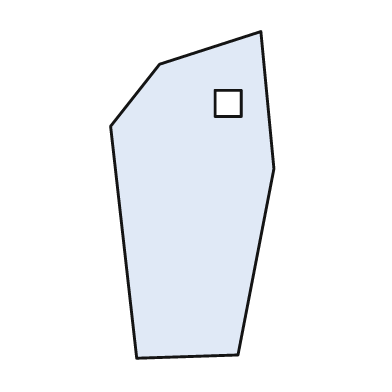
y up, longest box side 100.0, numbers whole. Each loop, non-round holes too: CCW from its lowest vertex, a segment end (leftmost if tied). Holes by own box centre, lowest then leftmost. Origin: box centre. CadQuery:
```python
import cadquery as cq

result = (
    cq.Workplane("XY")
    .moveTo(-17.0, -50.0)
    .lineTo(14.0, -49.0)
    .lineTo(25.0, 8.0)
    .lineTo(21.0, 50.0)
    .lineTo(-10.0, 40.0)
    .lineTo(-25.0, 21.0)
    .close()
    .moveTo(7.0, 24.0)
    .lineTo(15.0, 24.0)
    .lineTo(15.0, 32.0)
    .lineTo(7.0, 32.0)
    .close()
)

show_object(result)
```